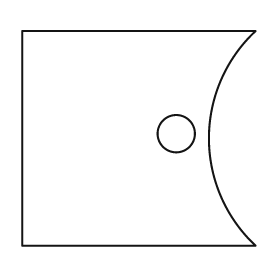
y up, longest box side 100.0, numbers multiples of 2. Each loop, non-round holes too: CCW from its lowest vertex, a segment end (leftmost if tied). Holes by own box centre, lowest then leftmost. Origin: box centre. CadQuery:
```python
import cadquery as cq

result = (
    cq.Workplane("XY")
    .moveTo(-50.0, -46.0)
    .lineTo(50.0, -46.0)
    .threePointArc((30.0, 0.0), (50.0, 46.0))
    .lineTo(-50.0, 46.0)
    .close()
    .moveTo(16.0, 2.0)
    .circle(8.0)
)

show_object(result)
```